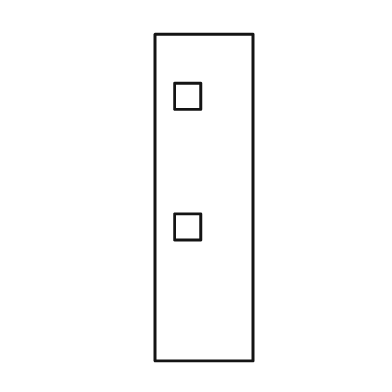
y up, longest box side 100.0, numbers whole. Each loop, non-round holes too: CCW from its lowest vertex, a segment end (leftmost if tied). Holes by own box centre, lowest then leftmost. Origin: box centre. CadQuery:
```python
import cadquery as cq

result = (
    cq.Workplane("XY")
    .moveTo(-15.0, -50.0)
    .lineTo(15.0, -50.0)
    .lineTo(15.0, 50.0)
    .lineTo(-15.0, 50.0)
    .close()
    .moveTo(-9.0, -13.0)
    .lineTo(-1.0, -13.0)
    .lineTo(-1.0, -5.0)
    .lineTo(-9.0, -5.0)
    .close()
    .moveTo(-9.0, 27.0)
    .lineTo(-1.0, 27.0)
    .lineTo(-1.0, 35.0)
    .lineTo(-9.0, 35.0)
    .close()
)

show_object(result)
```